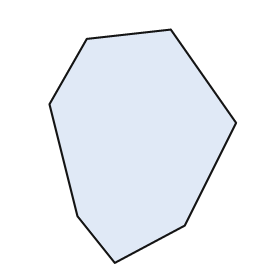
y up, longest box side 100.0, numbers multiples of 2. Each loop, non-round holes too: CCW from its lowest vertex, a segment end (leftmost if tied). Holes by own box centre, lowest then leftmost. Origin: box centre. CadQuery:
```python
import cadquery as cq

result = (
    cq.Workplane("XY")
    .moveTo(-12.0, -50.0)
    .lineTo(18.0, -34.0)
    .lineTo(40.0, 10.0)
    .lineTo(12.0, 50.0)
    .lineTo(-24.0, 46.0)
    .lineTo(-40.0, 18.0)
    .lineTo(-28.0, -30.0)
    .close()
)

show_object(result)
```